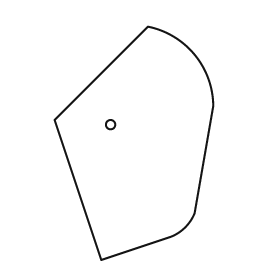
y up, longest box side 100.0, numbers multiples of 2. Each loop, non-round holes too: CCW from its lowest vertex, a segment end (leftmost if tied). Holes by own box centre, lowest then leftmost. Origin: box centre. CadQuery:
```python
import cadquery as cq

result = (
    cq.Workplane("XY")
    .moveTo(-14.0, -50.0)
    .lineTo(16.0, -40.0)
    .threePointArc((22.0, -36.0), (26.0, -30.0))
    .lineTo(34.0, 16.0)
    .threePointArc((26.0, 38.0), (6.0, 50.0))
    .lineTo(-34.0, 10.0)
    .close()
    .moveTo(-10.0, 8.0)
    .circle(2.0)
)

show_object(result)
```